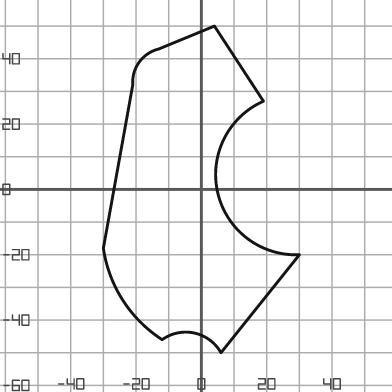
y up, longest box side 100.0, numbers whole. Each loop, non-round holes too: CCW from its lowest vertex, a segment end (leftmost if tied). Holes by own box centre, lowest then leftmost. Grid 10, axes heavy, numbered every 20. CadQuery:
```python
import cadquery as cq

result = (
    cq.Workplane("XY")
    .moveTo(6.0, -50.0)
    .lineTo(30.0, -20.0)
    .threePointArc((5.0, -1.0), (19.0, 27.0))
    .lineTo(4.0, 50.0)
    .lineTo(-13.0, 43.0)
    .threePointArc((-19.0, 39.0), (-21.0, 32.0))
    .lineTo(-30.0, -18.0)
    .threePointArc((-24.0, -34.0), (-12.0, -46.0))
    .threePointArc((-2.0, -44.0), (6.0, -50.0))
    .close()
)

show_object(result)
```